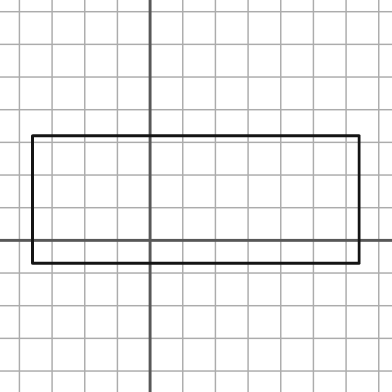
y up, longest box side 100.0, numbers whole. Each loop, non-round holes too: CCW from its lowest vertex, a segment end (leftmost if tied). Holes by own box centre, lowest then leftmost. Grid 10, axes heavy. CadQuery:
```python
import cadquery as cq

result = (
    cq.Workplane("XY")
    .moveTo(-36.0, -7.0)
    .lineTo(64.0, -7.0)
    .lineTo(64.0, 32.0)
    .lineTo(-36.0, 32.0)
    .close()
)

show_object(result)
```